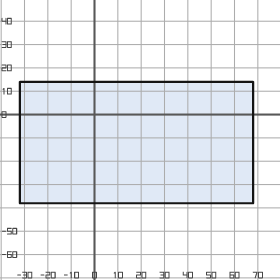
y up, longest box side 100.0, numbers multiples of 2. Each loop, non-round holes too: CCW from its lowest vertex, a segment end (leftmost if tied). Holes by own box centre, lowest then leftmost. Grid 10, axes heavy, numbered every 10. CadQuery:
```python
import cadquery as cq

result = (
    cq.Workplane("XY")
    .moveTo(-32.0, -38.0)
    .lineTo(68.0, -38.0)
    .lineTo(68.0, 14.0)
    .lineTo(-32.0, 14.0)
    .close()
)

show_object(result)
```